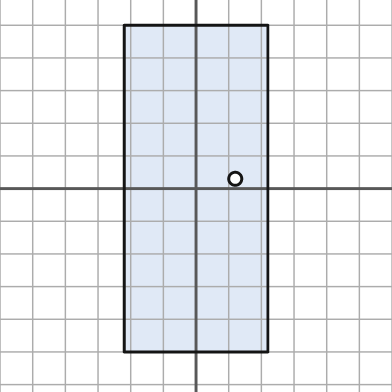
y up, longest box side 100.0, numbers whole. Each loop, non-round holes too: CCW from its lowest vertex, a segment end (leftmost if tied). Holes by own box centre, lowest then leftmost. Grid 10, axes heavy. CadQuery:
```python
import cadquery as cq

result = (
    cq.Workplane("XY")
    .moveTo(-22.0, -50.0)
    .lineTo(22.0, -50.0)
    .lineTo(22.0, 50.0)
    .lineTo(-22.0, 50.0)
    .close()
    .moveTo(12.0, 3.0)
    .circle(2.0)
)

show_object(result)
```